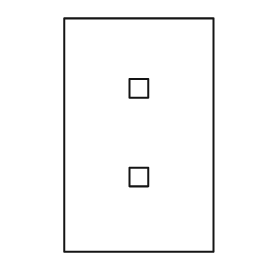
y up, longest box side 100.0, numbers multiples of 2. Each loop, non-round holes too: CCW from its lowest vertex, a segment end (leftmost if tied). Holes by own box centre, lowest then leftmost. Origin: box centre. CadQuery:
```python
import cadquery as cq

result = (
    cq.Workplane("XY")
    .moveTo(-32.0, -50.0)
    .lineTo(32.0, -50.0)
    .lineTo(32.0, 50.0)
    .lineTo(-32.0, 50.0)
    .close()
    .moveTo(-4.0, -22.0)
    .lineTo(4.0, -22.0)
    .lineTo(4.0, -14.0)
    .lineTo(-4.0, -14.0)
    .close()
    .moveTo(-4.0, 16.0)
    .lineTo(4.0, 16.0)
    .lineTo(4.0, 24.0)
    .lineTo(-4.0, 24.0)
    .close()
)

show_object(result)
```